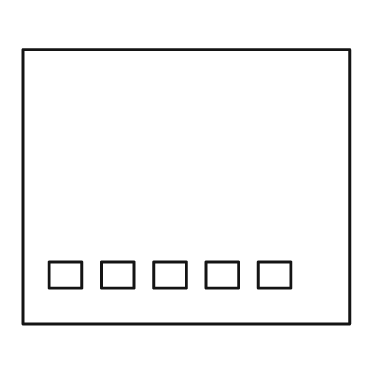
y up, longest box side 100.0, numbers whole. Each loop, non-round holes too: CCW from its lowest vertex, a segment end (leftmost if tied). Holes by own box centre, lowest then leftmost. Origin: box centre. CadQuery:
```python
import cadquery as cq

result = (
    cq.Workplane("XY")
    .moveTo(-50.0, -42.0)
    .lineTo(50.0, -42.0)
    .lineTo(50.0, 42.0)
    .lineTo(-50.0, 42.0)
    .close()
    .moveTo(-42.0, -31.0)
    .lineTo(-32.0, -31.0)
    .lineTo(-32.0, -23.0)
    .lineTo(-42.0, -23.0)
    .close()
    .moveTo(-26.0, -31.0)
    .lineTo(-16.0, -31.0)
    .lineTo(-16.0, -23.0)
    .lineTo(-26.0, -23.0)
    .close()
    .moveTo(-10.0, -31.0)
    .lineTo(0.0, -31.0)
    .lineTo(0.0, -23.0)
    .lineTo(-10.0, -23.0)
    .close()
    .moveTo(6.0, -31.0)
    .lineTo(16.0, -31.0)
    .lineTo(16.0, -23.0)
    .lineTo(6.0, -23.0)
    .close()
    .moveTo(22.0, -31.0)
    .lineTo(32.0, -31.0)
    .lineTo(32.0, -23.0)
    .lineTo(22.0, -23.0)
    .close()
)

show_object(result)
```